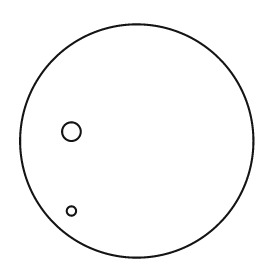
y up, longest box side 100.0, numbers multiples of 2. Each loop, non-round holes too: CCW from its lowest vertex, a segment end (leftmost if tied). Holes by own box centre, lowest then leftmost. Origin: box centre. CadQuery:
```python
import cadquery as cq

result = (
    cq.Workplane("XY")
    .moveTo(0.0, 0.0)
    .circle(50.0)
    .moveTo(-28.0, -30.0)
    .circle(2.0)
    .moveTo(-28.0, 4.0)
    .circle(4.0)
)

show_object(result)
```